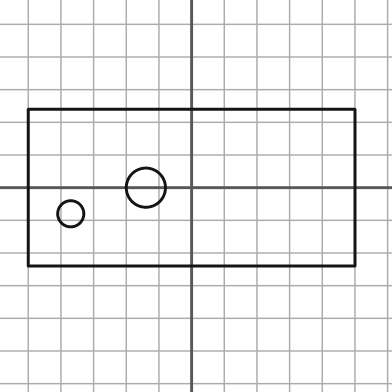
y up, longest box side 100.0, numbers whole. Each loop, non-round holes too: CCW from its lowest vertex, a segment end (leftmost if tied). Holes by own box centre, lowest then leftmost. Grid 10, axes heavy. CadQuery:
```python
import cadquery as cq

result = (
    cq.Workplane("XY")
    .moveTo(-50.0, -24.0)
    .lineTo(50.0, -24.0)
    .lineTo(50.0, 24.0)
    .lineTo(-50.0, 24.0)
    .close()
    .moveTo(-37.0, -8.0)
    .circle(4.0)
    .moveTo(-14.0, 0.0)
    .circle(6.0)
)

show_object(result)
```